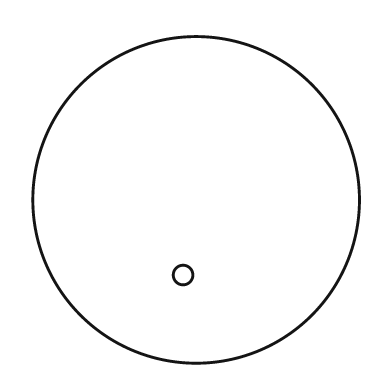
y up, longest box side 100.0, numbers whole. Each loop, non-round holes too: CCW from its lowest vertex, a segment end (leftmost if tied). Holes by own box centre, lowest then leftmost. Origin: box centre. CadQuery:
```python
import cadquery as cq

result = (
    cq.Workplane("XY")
    .moveTo(0.0, 0.0)
    .circle(50.0)
    .moveTo(-4.0, -23.0)
    .circle(3.0)
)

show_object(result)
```